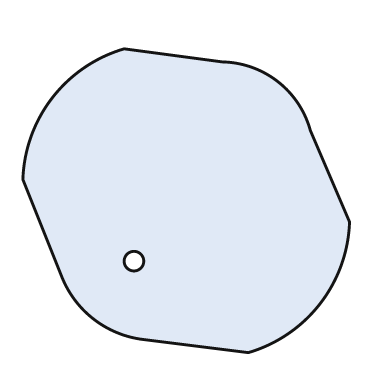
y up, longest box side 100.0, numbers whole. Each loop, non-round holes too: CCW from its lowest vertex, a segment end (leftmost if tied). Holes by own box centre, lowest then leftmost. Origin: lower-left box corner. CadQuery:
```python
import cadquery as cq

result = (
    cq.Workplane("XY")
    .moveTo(69.0, 0.0)
    .threePointArc((91.0, 15.0), (100.0, 40.0))
    .lineTo(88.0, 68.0)
    .threePointArc((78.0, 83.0), (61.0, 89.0))
    .lineTo(31.0, 93.0)
    .threePointArc((9.0, 78.0), (0.0, 53.0))
    .lineTo(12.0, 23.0)
    .threePointArc((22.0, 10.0), (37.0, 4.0))
    .close()
    .moveTo(34.0, 28.0)
    .circle(3.0)
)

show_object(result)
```